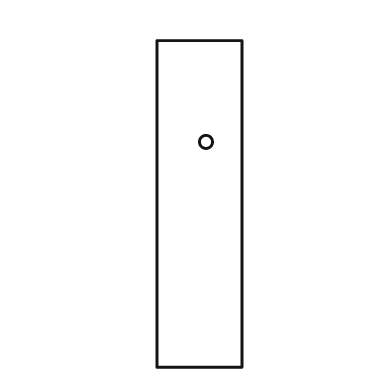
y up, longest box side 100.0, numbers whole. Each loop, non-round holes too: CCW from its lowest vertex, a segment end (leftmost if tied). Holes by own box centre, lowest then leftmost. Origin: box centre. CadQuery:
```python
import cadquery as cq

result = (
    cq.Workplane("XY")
    .moveTo(-13.0, -50.0)
    .lineTo(13.0, -50.0)
    .lineTo(13.0, 50.0)
    .lineTo(-13.0, 50.0)
    .close()
    .moveTo(2.0, 19.0)
    .circle(2.0)
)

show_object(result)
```